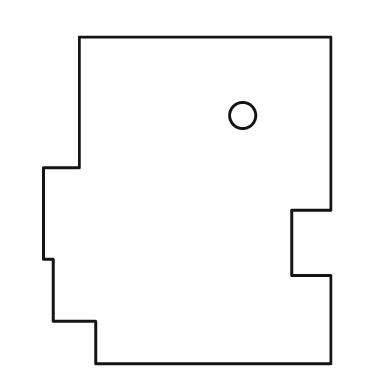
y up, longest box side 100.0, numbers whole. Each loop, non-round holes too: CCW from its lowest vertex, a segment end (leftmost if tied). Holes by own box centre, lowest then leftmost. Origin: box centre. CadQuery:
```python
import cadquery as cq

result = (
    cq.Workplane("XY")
    .moveTo(-28.0, -50.0)
    .lineTo(44.0, -50.0)
    .lineTo(44.0, -23.0)
    .lineTo(32.0, -23.0)
    .lineTo(32.0, -3.0)
    .lineTo(44.0, -3.0)
    .lineTo(44.0, 50.0)
    .lineTo(-33.0, 50.0)
    .lineTo(-33.0, 10.0)
    .lineTo(-44.0, 10.0)
    .lineTo(-44.0, -18.0)
    .lineTo(-41.0, -18.0)
    .lineTo(-41.0, -37.0)
    .lineTo(-28.0, -37.0)
    .close()
    .moveTo(17.0, 26.0)
    .circle(4.0)
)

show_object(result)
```